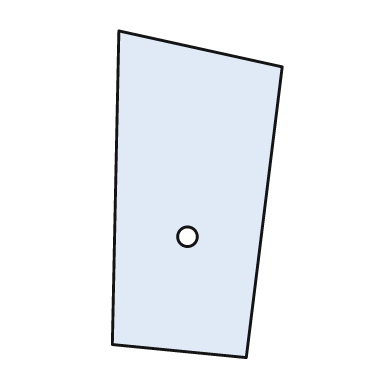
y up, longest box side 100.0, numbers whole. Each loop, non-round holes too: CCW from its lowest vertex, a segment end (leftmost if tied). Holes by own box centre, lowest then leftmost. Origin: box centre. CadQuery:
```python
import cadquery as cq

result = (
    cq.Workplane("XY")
    .moveTo(15.0, -50.0)
    .lineTo(26.0, 39.0)
    .lineTo(-24.0, 50.0)
    .lineTo(-26.0, -46.0)
    .close()
    .moveTo(-3.0, -13.0)
    .circle(3.0)
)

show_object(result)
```